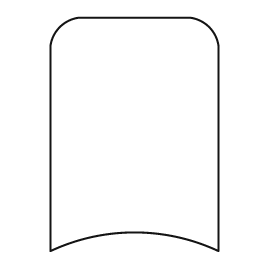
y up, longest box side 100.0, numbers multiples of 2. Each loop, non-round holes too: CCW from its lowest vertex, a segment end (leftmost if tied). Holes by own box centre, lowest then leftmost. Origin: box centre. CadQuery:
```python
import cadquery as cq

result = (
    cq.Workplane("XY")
    .moveTo(-36.0, -50.0)
    .threePointArc((0.0, -42.0), (36.0, -50.0))
    .lineTo(36.0, 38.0)
    .threePointArc((32.0, 46.0), (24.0, 50.0))
    .lineTo(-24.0, 50.0)
    .threePointArc((-32.0, 46.0), (-36.0, 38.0))
    .close()
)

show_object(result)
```